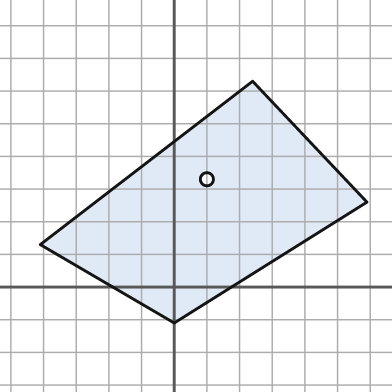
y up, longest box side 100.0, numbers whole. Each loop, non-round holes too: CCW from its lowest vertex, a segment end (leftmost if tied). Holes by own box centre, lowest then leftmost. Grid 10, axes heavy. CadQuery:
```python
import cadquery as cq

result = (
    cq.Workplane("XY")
    .moveTo(0.0, -11.0)
    .lineTo(59.0, 26.0)
    .lineTo(24.0, 63.0)
    .lineTo(-41.0, 13.0)
    .close()
    .moveTo(10.0, 33.0)
    .circle(2.0)
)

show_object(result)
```